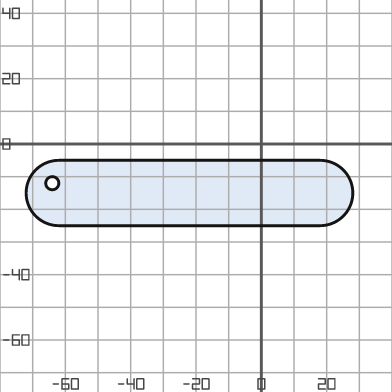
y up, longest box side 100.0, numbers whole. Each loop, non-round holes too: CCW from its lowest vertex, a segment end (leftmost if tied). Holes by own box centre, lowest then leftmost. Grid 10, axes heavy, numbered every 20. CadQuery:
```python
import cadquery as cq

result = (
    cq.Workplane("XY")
    .moveTo(-62.0, -25.0)
    .lineTo(18.0, -25.0)
    .threePointArc((28.0, -15.0), (18.0, -5.0))
    .lineTo(-62.0, -5.0)
    .threePointArc((-72.0, -15.0), (-62.0, -25.0))
    .close()
    .moveTo(-64.0, -12.0)
    .circle(2.0)
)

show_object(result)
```